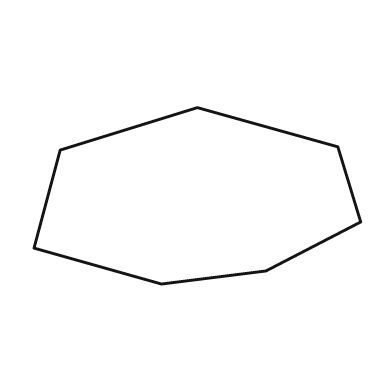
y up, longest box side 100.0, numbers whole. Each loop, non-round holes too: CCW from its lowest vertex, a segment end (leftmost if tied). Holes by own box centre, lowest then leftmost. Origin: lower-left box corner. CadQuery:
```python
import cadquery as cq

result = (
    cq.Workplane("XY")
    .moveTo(39.0, 0.0)
    .lineTo(71.0, 4.0)
    .lineTo(100.0, 19.0)
    .lineTo(93.0, 42.0)
    .lineTo(50.0, 54.0)
    .lineTo(8.0, 41.0)
    .lineTo(0.0, 11.0)
    .close()
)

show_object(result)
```